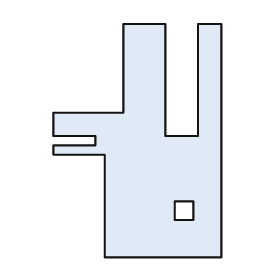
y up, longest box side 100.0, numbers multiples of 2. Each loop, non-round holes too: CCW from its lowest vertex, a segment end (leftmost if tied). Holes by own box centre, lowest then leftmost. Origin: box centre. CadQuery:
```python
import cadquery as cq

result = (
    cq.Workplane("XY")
    .moveTo(-14.0, -50.0)
    .lineTo(36.0, -50.0)
    .lineTo(36.0, 50.0)
    .lineTo(26.0, 50.0)
    .lineTo(26.0, 2.0)
    .lineTo(12.0, 2.0)
    .lineTo(12.0, 50.0)
    .lineTo(-6.0, 50.0)
    .lineTo(-6.0, 12.0)
    .lineTo(-36.0, 12.0)
    .lineTo(-36.0, 2.0)
    .lineTo(-18.0, 2.0)
    .lineTo(-18.0, -2.0)
    .lineTo(-36.0, -2.0)
    .lineTo(-36.0, -6.0)
    .lineTo(-14.0, -6.0)
    .close()
    .moveTo(16.0, -34.0)
    .lineTo(24.0, -34.0)
    .lineTo(24.0, -26.0)
    .lineTo(16.0, -26.0)
    .close()
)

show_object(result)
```